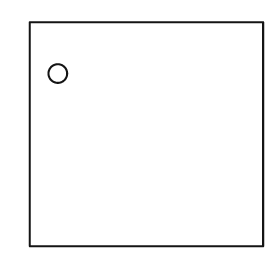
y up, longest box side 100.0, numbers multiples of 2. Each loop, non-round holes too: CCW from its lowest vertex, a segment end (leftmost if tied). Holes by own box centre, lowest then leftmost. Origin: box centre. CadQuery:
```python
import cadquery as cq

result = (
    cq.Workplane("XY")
    .moveTo(-50.0, -48.0)
    .lineTo(50.0, -48.0)
    .lineTo(50.0, 48.0)
    .lineTo(-50.0, 48.0)
    .close()
    .moveTo(-38.0, 26.0)
    .circle(4.0)
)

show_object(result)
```